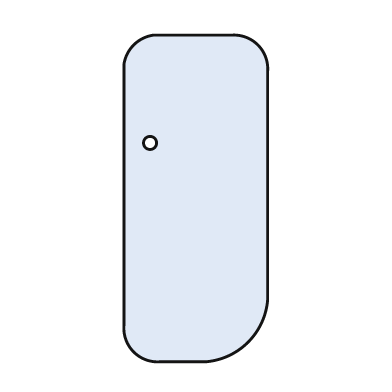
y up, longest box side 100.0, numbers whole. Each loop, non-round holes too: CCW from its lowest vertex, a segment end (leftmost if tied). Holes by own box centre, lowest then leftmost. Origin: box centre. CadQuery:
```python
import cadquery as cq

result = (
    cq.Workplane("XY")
    .moveTo(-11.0, -50.0)
    .lineTo(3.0, -50.0)
    .threePointArc((16.0, -44.0), (22.0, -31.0))
    .lineTo(22.0, 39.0)
    .threePointArc((19.0, 47.0), (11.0, 50.0))
    .lineTo(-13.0, 50.0)
    .threePointArc((-19.0, 47.0), (-22.0, 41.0))
    .lineTo(-22.0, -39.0)
    .threePointArc((-19.0, -47.0), (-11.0, -50.0))
    .close()
    .moveTo(-14.0, 17.0)
    .circle(2.0)
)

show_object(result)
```